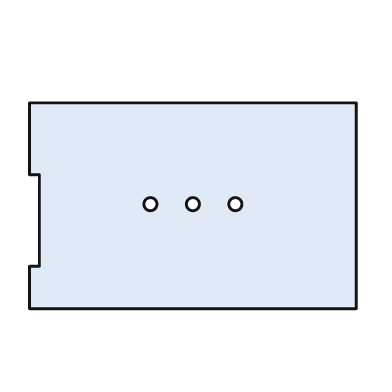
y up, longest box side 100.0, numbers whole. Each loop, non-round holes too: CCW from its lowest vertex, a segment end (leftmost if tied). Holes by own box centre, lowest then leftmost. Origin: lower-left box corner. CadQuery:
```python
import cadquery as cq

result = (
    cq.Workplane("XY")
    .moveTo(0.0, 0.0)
    .lineTo(100.0, 0.0)
    .lineTo(100.0, 63.0)
    .lineTo(0.0, 63.0)
    .lineTo(0.0, 41.0)
    .lineTo(3.0, 41.0)
    .lineTo(3.0, 13.0)
    .lineTo(0.0, 13.0)
    .close()
    .moveTo(37.0, 32.0)
    .circle(2.0)
    .moveTo(50.0, 32.0)
    .circle(2.0)
    .moveTo(63.0, 32.0)
    .circle(2.0)
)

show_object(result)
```